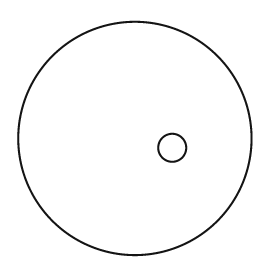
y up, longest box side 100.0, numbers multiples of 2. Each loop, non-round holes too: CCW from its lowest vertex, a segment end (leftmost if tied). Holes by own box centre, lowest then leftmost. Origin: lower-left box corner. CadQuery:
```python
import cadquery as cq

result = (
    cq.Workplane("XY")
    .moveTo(50.0, 50.0)
    .circle(50.0)
    .moveTo(66.0, 46.0)
    .circle(6.0)
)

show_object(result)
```